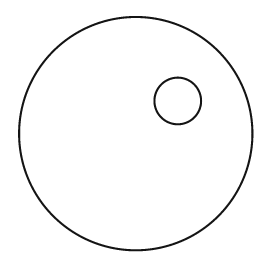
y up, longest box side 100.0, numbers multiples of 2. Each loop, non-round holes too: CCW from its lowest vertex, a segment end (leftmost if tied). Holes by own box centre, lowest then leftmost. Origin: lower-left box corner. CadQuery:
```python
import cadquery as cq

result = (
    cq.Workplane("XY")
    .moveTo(50.0, 50.0)
    .circle(50.0)
    .moveTo(68.0, 64.0)
    .circle(10.0)
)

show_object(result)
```